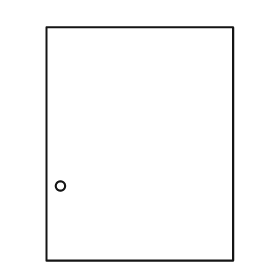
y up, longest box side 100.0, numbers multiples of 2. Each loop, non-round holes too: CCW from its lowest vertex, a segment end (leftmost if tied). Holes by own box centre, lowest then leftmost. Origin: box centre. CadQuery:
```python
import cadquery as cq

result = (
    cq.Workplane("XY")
    .moveTo(-40.0, -50.0)
    .lineTo(40.0, -50.0)
    .lineTo(40.0, 50.0)
    .lineTo(-40.0, 50.0)
    .close()
    .moveTo(-34.0, -18.0)
    .circle(2.0)
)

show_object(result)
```